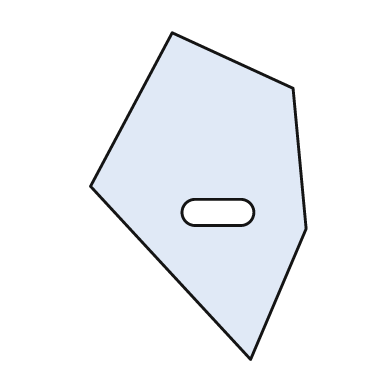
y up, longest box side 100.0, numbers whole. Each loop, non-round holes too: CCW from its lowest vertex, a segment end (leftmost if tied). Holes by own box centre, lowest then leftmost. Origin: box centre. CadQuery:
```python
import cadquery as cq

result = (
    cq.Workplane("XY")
    .moveTo(16.0, -50.0)
    .lineTo(33.0, -10.0)
    .lineTo(29.0, 33.0)
    .lineTo(-8.0, 50.0)
    .lineTo(-33.0, 3.0)
    .close()
    .moveTo(-1.0, -9.0)
    .lineTo(13.0, -9.0)
    .threePointArc((17.0, -5.0), (13.0, -1.0))
    .lineTo(-1.0, -1.0)
    .threePointArc((-5.0, -5.0), (-1.0, -9.0))
    .close()
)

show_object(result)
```